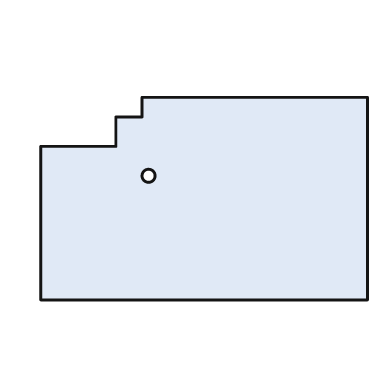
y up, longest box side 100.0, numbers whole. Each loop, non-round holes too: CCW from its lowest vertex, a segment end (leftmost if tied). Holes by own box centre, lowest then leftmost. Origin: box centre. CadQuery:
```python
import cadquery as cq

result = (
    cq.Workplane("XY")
    .moveTo(-50.0, -31.0)
    .lineTo(50.0, -31.0)
    .lineTo(50.0, 31.0)
    .lineTo(-19.0, 31.0)
    .lineTo(-19.0, 25.0)
    .lineTo(-27.0, 25.0)
    .lineTo(-27.0, 16.0)
    .lineTo(-50.0, 16.0)
    .close()
    .moveTo(-17.0, 7.0)
    .circle(2.0)
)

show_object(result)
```